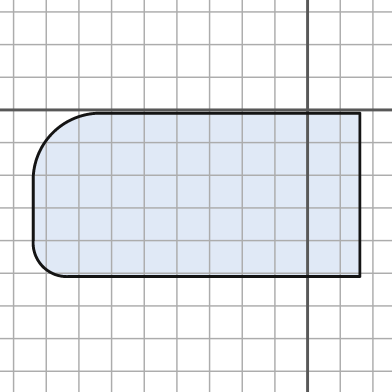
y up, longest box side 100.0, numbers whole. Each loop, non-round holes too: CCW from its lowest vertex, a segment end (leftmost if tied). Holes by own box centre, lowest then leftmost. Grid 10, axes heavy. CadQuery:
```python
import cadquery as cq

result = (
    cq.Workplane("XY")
    .moveTo(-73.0, -51.0)
    .lineTo(16.0, -51.0)
    .lineTo(16.0, -1.0)
    .lineTo(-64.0, -1.0)
    .threePointArc((-78.0, -7.0), (-84.0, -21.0))
    .lineTo(-84.0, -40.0)
    .threePointArc((-81.0, -48.0), (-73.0, -51.0))
    .close()
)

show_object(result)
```